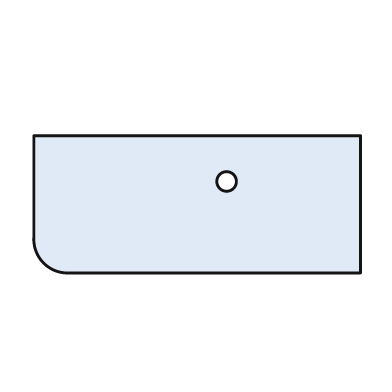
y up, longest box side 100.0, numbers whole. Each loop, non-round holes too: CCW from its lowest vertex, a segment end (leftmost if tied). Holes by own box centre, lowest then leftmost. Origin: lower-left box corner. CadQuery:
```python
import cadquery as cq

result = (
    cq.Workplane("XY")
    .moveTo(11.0, 0.0)
    .lineTo(100.0, 0.0)
    .lineTo(100.0, 42.0)
    .lineTo(0.0, 42.0)
    .lineTo(0.0, 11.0)
    .threePointArc((3.0, 3.0), (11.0, 0.0))
    .close()
    .moveTo(59.0, 28.0)
    .circle(3.0)
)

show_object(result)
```